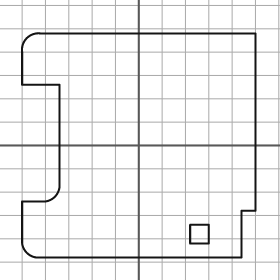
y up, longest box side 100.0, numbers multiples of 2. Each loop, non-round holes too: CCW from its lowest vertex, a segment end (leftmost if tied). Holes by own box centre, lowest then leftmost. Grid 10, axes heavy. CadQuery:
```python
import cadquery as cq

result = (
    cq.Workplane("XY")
    .moveTo(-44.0, -48.0)
    .lineTo(44.0, -48.0)
    .lineTo(44.0, -28.0)
    .lineTo(50.0, -28.0)
    .lineTo(50.0, 48.0)
    .lineTo(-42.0, 48.0)
    .threePointArc((-48.0, 46.0), (-50.0, 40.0))
    .lineTo(-50.0, 26.0)
    .lineTo(-34.0, 26.0)
    .lineTo(-34.0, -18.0)
    .threePointArc((-36.0, -22.0), (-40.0, -24.0))
    .lineTo(-50.0, -24.0)
    .lineTo(-50.0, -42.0)
    .threePointArc((-48.0, -46.0), (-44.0, -48.0))
    .close()
    .moveTo(22.0, -42.0)
    .lineTo(30.0, -42.0)
    .lineTo(30.0, -34.0)
    .lineTo(22.0, -34.0)
    .close()
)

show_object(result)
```